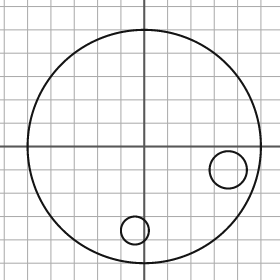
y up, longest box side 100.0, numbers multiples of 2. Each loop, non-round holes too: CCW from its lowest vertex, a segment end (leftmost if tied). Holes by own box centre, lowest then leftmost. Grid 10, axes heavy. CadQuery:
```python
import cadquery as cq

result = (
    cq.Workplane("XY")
    .moveTo(0.0, 0.0)
    .circle(50.0)
    .moveTo(-4.0, -36.0)
    .circle(6.0)
    .moveTo(36.0, -10.0)
    .circle(8.0)
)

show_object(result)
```